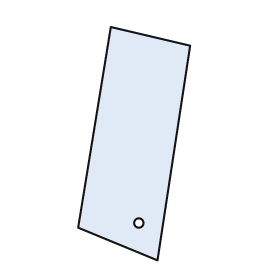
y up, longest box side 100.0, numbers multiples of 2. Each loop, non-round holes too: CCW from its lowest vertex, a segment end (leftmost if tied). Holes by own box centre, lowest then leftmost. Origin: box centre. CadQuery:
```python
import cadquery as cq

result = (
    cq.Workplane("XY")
    .moveTo(10.0, -50.0)
    .lineTo(24.0, 42.0)
    .lineTo(-10.0, 50.0)
    .lineTo(-24.0, -36.0)
    .close()
    .moveTo(2.0, -34.0)
    .circle(2.0)
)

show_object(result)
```